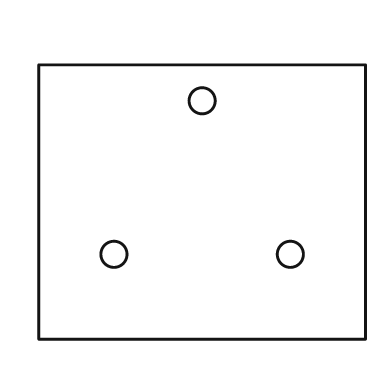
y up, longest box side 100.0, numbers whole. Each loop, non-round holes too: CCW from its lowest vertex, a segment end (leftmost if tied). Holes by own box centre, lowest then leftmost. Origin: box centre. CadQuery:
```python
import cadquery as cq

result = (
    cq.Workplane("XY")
    .moveTo(-50.0, -42.0)
    .lineTo(50.0, -42.0)
    .lineTo(50.0, 42.0)
    .lineTo(-50.0, 42.0)
    .close()
    .moveTo(-27.0, -16.0)
    .circle(4.0)
    .moveTo(27.0, -16.0)
    .circle(4.0)
    .moveTo(0.0, 31.0)
    .circle(4.0)
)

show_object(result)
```